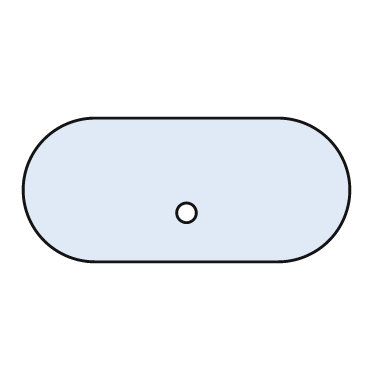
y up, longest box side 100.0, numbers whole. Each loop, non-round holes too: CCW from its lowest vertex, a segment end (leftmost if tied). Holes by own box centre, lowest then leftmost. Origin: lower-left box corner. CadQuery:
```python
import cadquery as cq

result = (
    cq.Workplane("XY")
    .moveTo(22.0, 0.0)
    .lineTo(78.0, 0.0)
    .threePointArc((100.0, 22.0), (78.0, 44.0))
    .lineTo(22.0, 44.0)
    .threePointArc((0.0, 22.0), (22.0, 0.0))
    .close()
    .moveTo(50.0, 15.0)
    .circle(3.0)
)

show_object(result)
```